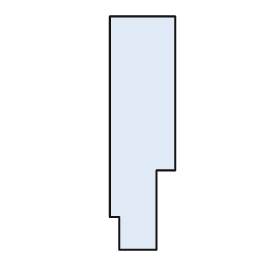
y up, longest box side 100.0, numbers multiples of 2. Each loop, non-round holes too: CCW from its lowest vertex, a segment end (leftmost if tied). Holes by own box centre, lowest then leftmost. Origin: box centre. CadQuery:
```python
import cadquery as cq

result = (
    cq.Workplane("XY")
    .moveTo(-10.0, -50.0)
    .lineTo(6.0, -50.0)
    .lineTo(6.0, -16.0)
    .lineTo(14.0, -16.0)
    .lineTo(14.0, 50.0)
    .lineTo(-14.0, 50.0)
    .lineTo(-14.0, -36.0)
    .lineTo(-10.0, -36.0)
    .close()
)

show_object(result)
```